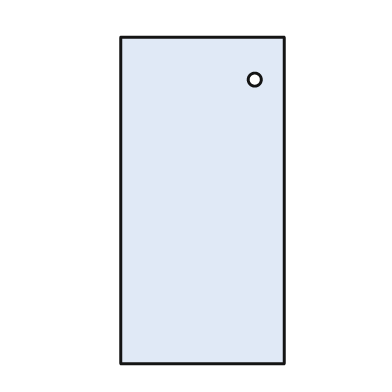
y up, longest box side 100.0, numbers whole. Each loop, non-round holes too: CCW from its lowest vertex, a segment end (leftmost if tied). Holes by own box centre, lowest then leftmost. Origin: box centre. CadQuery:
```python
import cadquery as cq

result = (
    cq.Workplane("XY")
    .moveTo(-25.0, -50.0)
    .lineTo(25.0, -50.0)
    .lineTo(25.0, 50.0)
    .lineTo(-25.0, 50.0)
    .close()
    .moveTo(16.0, 37.0)
    .circle(2.0)
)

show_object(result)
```